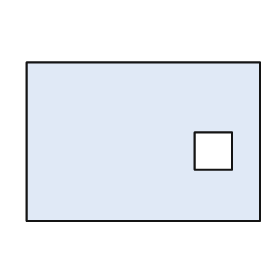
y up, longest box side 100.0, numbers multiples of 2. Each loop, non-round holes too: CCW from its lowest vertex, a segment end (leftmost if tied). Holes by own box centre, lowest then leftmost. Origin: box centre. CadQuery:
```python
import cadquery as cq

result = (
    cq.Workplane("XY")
    .moveTo(-50.0, -34.0)
    .lineTo(50.0, -34.0)
    .lineTo(50.0, 34.0)
    .lineTo(-50.0, 34.0)
    .close()
    .moveTo(22.0, -12.0)
    .lineTo(38.0, -12.0)
    .lineTo(38.0, 4.0)
    .lineTo(22.0, 4.0)
    .close()
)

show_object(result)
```